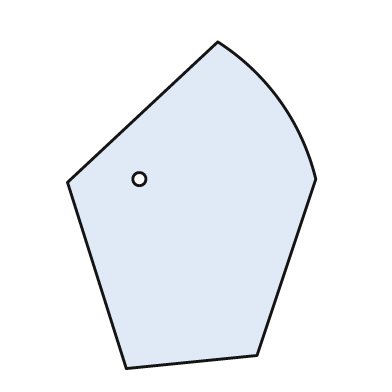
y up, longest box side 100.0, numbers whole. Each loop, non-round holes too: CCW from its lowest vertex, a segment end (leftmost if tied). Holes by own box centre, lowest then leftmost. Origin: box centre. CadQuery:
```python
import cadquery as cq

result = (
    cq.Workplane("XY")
    .moveTo(-20.0, -50.0)
    .lineTo(20.0, -46.0)
    .lineTo(38.0, 8.0)
    .threePointArc((27.0, 32.0), (8.0, 50.0))
    .lineTo(-38.0, 7.0)
    .close()
    .moveTo(-16.0, 8.0)
    .circle(2.0)
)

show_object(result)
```